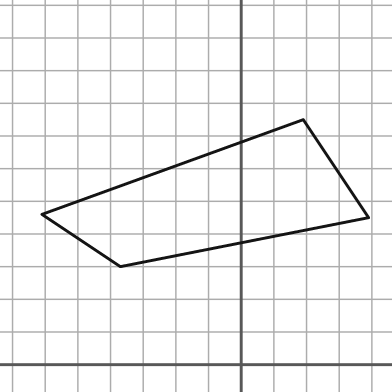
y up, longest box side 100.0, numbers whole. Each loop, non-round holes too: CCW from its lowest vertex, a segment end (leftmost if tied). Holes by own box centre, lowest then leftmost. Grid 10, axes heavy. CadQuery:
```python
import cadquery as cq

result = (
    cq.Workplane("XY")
    .moveTo(-37.0, 30.0)
    .lineTo(39.0, 45.0)
    .lineTo(19.0, 75.0)
    .lineTo(-61.0, 46.0)
    .close()
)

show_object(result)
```